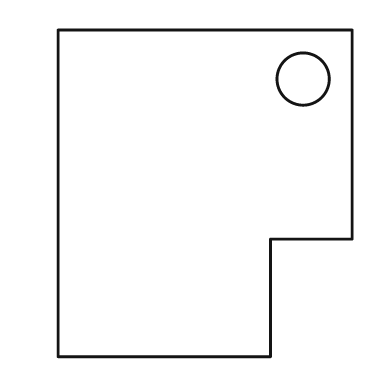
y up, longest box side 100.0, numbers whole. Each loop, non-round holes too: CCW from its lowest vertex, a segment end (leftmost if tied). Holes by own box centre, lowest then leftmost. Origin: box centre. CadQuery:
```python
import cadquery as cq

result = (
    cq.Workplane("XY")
    .moveTo(-45.0, -50.0)
    .lineTo(20.0, -50.0)
    .lineTo(20.0, -14.0)
    .lineTo(45.0, -14.0)
    .lineTo(45.0, 50.0)
    .lineTo(-45.0, 50.0)
    .close()
    .moveTo(30.0, 35.0)
    .circle(8.0)
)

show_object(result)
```